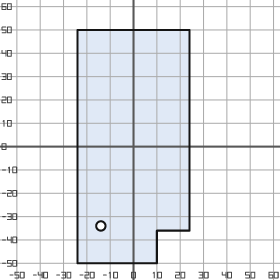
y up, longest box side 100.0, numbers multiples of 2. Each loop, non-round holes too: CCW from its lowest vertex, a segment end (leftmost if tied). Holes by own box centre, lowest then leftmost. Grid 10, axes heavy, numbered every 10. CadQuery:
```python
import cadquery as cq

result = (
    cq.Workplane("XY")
    .moveTo(-24.0, -50.0)
    .lineTo(10.0, -50.0)
    .lineTo(10.0, -36.0)
    .lineTo(24.0, -36.0)
    .lineTo(24.0, 50.0)
    .lineTo(-24.0, 50.0)
    .close()
    .moveTo(-14.0, -34.0)
    .circle(2.0)
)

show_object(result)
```